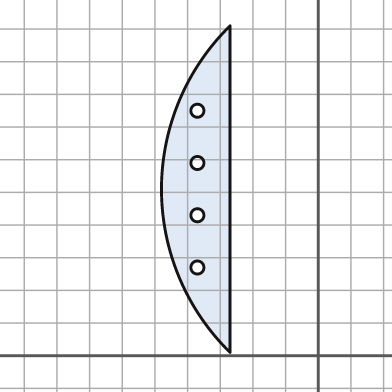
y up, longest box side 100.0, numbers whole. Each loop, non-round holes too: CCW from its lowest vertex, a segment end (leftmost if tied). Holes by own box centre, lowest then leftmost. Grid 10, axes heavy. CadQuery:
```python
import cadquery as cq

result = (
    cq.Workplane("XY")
    .moveTo(-27.0, 1.0)
    .lineTo(-27.0, 101.0)
    .threePointArc((-48.0, 51.0), (-27.0, 1.0))
    .close()
    .moveTo(-37.0, 27.0)
    .circle(2.0)
    .moveTo(-37.0, 43.0)
    .circle(2.0)
    .moveTo(-37.0, 59.0)
    .circle(2.0)
    .moveTo(-37.0, 75.0)
    .circle(2.0)
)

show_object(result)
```